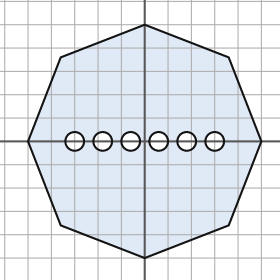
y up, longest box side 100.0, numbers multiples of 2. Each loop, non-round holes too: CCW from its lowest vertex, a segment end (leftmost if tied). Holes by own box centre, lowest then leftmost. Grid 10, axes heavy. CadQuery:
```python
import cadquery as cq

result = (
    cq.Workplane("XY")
    .moveTo(0.0, -50.0)
    .lineTo(36.0, -36.0)
    .lineTo(50.0, 0.0)
    .lineTo(36.0, 36.0)
    .lineTo(0.0, 50.0)
    .lineTo(-36.0, 36.0)
    .lineTo(-50.0, 0.0)
    .lineTo(-36.0, -36.0)
    .close()
    .moveTo(-30.0, 0.0)
    .circle(4.0)
    .moveTo(-18.0, 0.0)
    .circle(4.0)
    .moveTo(-6.0, 0.0)
    .circle(4.0)
    .moveTo(6.0, 0.0)
    .circle(4.0)
    .moveTo(18.0, 0.0)
    .circle(4.0)
    .moveTo(30.0, 0.0)
    .circle(4.0)
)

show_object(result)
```